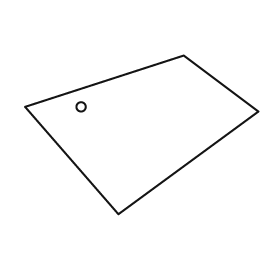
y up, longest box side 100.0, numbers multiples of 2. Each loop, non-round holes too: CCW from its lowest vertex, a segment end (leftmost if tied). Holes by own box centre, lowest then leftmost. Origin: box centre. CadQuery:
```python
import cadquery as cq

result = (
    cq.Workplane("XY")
    .moveTo(-10.0, -34.0)
    .lineTo(50.0, 10.0)
    .lineTo(18.0, 34.0)
    .lineTo(-50.0, 12.0)
    .close()
    .moveTo(-26.0, 12.0)
    .circle(2.0)
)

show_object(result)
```